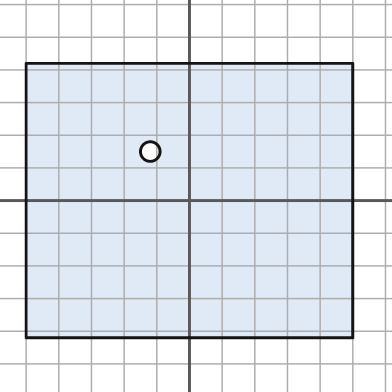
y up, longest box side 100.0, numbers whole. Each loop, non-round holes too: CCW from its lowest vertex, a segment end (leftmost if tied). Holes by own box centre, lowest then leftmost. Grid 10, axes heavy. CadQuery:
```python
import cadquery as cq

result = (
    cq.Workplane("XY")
    .moveTo(-50.0, -42.0)
    .lineTo(50.0, -42.0)
    .lineTo(50.0, 42.0)
    .lineTo(-50.0, 42.0)
    .close()
    .moveTo(-12.0, 15.0)
    .circle(3.0)
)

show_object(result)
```